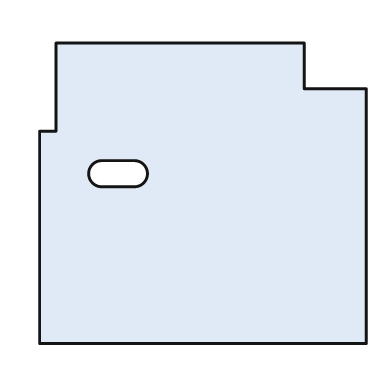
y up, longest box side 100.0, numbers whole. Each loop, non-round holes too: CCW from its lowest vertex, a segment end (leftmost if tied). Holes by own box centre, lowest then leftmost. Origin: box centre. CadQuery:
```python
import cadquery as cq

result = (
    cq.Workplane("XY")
    .moveTo(-50.0, -46.0)
    .lineTo(50.0, -46.0)
    .lineTo(50.0, 32.0)
    .lineTo(31.0, 32.0)
    .lineTo(31.0, 46.0)
    .lineTo(-45.0, 46.0)
    .lineTo(-45.0, 19.0)
    .lineTo(-50.0, 19.0)
    .close()
    .moveTo(-31.0, 2.0)
    .lineTo(-21.0, 2.0)
    .threePointArc((-17.0, 6.0), (-21.0, 10.0))
    .lineTo(-31.0, 10.0)
    .threePointArc((-35.0, 6.0), (-31.0, 2.0))
    .close()
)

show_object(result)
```